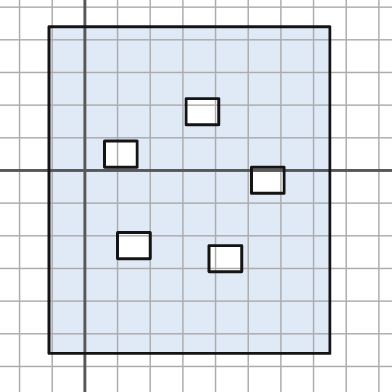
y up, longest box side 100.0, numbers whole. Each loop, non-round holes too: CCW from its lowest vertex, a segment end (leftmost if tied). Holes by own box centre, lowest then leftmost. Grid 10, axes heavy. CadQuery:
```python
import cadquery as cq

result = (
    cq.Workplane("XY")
    .moveTo(-11.0, -56.0)
    .lineTo(75.0, -56.0)
    .lineTo(75.0, 44.0)
    .lineTo(-11.0, 44.0)
    .close()
    .moveTo(38.0, -31.0)
    .lineTo(48.0, -31.0)
    .lineTo(48.0, -23.0)
    .lineTo(38.0, -23.0)
    .close()
    .moveTo(10.0, -27.0)
    .lineTo(20.0, -27.0)
    .lineTo(20.0, -19.0)
    .lineTo(10.0, -19.0)
    .close()
    .moveTo(51.0, -7.0)
    .lineTo(61.0, -7.0)
    .lineTo(61.0, 1.0)
    .lineTo(51.0, 1.0)
    .close()
    .moveTo(6.0, 1.0)
    .lineTo(16.0, 1.0)
    .lineTo(16.0, 9.0)
    .lineTo(6.0, 9.0)
    .close()
    .moveTo(31.0, 14.0)
    .lineTo(41.0, 14.0)
    .lineTo(41.0, 22.0)
    .lineTo(31.0, 22.0)
    .close()
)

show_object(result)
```